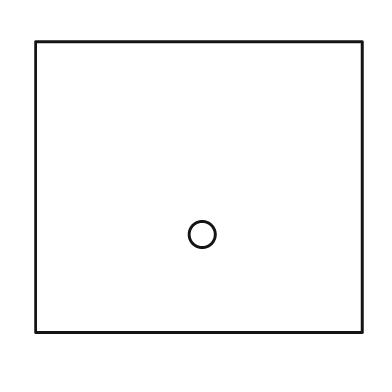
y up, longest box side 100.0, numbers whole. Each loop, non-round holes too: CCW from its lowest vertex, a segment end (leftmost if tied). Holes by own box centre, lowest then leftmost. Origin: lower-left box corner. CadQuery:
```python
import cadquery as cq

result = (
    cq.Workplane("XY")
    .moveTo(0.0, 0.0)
    .lineTo(100.0, 0.0)
    .lineTo(100.0, 89.0)
    .lineTo(0.0, 89.0)
    .close()
    .moveTo(51.0, 30.0)
    .circle(4.0)
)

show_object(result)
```